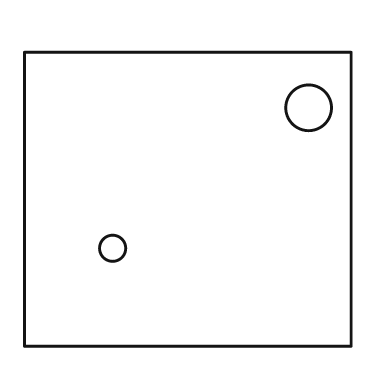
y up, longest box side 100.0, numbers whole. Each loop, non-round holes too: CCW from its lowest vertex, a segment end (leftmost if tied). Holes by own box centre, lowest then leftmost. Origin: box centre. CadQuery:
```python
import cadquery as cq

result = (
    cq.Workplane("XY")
    .moveTo(-50.0, -45.0)
    .lineTo(50.0, -45.0)
    .lineTo(50.0, 45.0)
    .lineTo(-50.0, 45.0)
    .close()
    .moveTo(-23.0, -15.0)
    .circle(4.0)
    .moveTo(37.0, 28.0)
    .circle(7.0)
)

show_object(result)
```